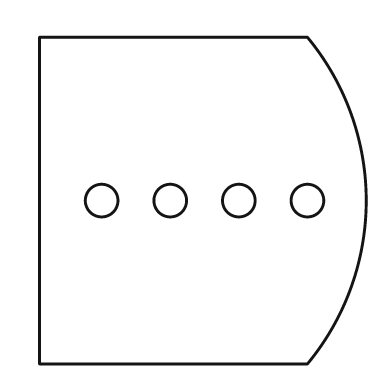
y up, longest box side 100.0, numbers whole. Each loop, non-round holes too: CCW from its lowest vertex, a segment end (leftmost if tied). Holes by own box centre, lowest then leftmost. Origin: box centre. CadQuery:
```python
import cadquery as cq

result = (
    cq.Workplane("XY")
    .moveTo(-50.0, -50.0)
    .lineTo(32.0, -50.0)
    .threePointArc((50.0, 0.0), (32.0, 50.0))
    .lineTo(-50.0, 50.0)
    .close()
    .moveTo(-31.0, 0.0)
    .circle(5.0)
    .moveTo(-10.0, 0.0)
    .circle(5.0)
    .moveTo(11.0, 0.0)
    .circle(5.0)
    .moveTo(32.0, 0.0)
    .circle(5.0)
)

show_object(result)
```